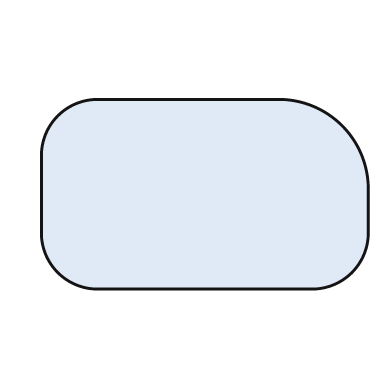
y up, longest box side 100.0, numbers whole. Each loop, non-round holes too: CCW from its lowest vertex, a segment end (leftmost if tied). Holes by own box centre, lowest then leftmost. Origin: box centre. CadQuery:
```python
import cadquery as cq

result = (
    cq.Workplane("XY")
    .moveTo(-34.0, -29.0)
    .lineTo(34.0, -29.0)
    .threePointArc((45.0, -24.0), (50.0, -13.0))
    .lineTo(50.0, 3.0)
    .threePointArc((42.0, 21.0), (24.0, 29.0))
    .lineTo(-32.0, 29.0)
    .threePointArc((-45.0, 24.0), (-50.0, 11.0))
    .lineTo(-50.0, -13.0)
    .threePointArc((-45.0, -24.0), (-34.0, -29.0))
    .close()
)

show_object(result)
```